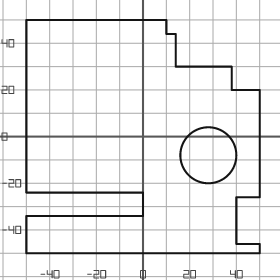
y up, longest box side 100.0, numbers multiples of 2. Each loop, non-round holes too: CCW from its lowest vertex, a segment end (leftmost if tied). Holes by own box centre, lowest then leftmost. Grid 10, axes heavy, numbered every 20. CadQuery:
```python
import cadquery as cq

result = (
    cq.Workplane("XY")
    .moveTo(-50.0, -50.0)
    .lineTo(50.0, -50.0)
    .lineTo(50.0, -46.0)
    .lineTo(40.0, -46.0)
    .lineTo(40.0, -26.0)
    .lineTo(50.0, -26.0)
    .lineTo(50.0, 20.0)
    .lineTo(38.0, 20.0)
    .lineTo(38.0, 30.0)
    .lineTo(14.0, 30.0)
    .lineTo(14.0, 44.0)
    .lineTo(10.0, 44.0)
    .lineTo(10.0, 50.0)
    .lineTo(-50.0, 50.0)
    .lineTo(-50.0, -24.0)
    .lineTo(0.0, -24.0)
    .lineTo(0.0, -34.0)
    .lineTo(-50.0, -34.0)
    .close()
    .moveTo(28.0, -8.0)
    .circle(12.0)
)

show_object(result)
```